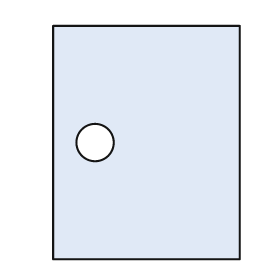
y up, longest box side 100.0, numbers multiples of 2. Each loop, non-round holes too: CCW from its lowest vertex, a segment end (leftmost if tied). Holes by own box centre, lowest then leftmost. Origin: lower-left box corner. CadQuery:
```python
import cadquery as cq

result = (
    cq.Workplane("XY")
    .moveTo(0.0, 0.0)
    .lineTo(80.0, 0.0)
    .lineTo(80.0, 100.0)
    .lineTo(0.0, 100.0)
    .close()
    .moveTo(18.0, 50.0)
    .circle(8.0)
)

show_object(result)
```